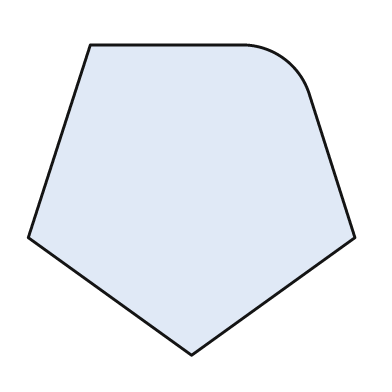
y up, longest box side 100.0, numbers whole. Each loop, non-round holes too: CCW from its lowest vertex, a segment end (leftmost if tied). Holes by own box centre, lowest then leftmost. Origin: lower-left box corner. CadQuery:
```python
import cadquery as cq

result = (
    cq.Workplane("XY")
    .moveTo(50.0, 0.0)
    .lineTo(100.0, 36.0)
    .lineTo(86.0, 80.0)
    .threePointArc((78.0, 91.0), (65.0, 95.0))
    .lineTo(19.0, 95.0)
    .lineTo(0.0, 36.0)
    .close()
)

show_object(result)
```